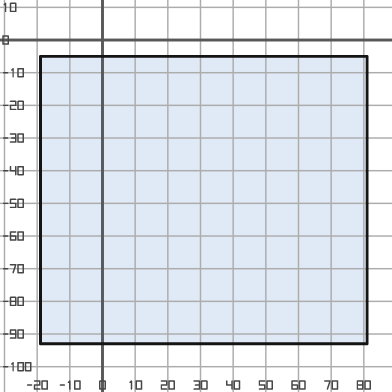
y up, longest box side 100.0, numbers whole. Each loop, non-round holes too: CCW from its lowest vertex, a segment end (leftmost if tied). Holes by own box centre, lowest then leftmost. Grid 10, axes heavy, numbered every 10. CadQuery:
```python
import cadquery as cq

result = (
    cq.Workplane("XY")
    .moveTo(-19.0, -93.0)
    .lineTo(81.0, -93.0)
    .lineTo(81.0, -5.0)
    .lineTo(-19.0, -5.0)
    .close()
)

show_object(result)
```